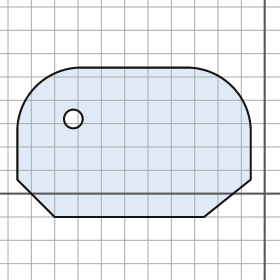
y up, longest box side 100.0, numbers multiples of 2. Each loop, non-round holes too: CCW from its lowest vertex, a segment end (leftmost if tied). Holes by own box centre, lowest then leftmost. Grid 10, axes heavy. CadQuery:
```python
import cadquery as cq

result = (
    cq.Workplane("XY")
    .moveTo(-90.0, -10.0)
    .lineTo(-26.0, -10.0)
    .lineTo(-6.0, 6.0)
    .lineTo(-6.0, 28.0)
    .threePointArc((-14.0, 46.0), (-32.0, 54.0))
    .lineTo(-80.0, 54.0)
    .threePointArc((-98.0, 46.0), (-106.0, 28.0))
    .lineTo(-106.0, 6.0)
    .close()
    .moveTo(-82.0, 32.0)
    .circle(4.0)
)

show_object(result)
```